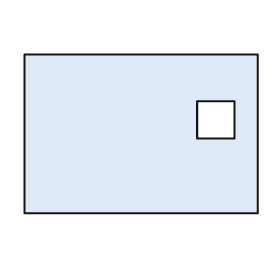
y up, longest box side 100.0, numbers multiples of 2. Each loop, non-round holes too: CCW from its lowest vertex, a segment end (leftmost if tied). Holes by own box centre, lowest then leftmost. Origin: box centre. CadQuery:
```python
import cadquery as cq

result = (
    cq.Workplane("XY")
    .moveTo(-50.0, -34.0)
    .lineTo(50.0, -34.0)
    .lineTo(50.0, 34.0)
    .lineTo(-50.0, 34.0)
    .close()
    .moveTo(24.0, -2.0)
    .lineTo(40.0, -2.0)
    .lineTo(40.0, 14.0)
    .lineTo(24.0, 14.0)
    .close()
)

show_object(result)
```